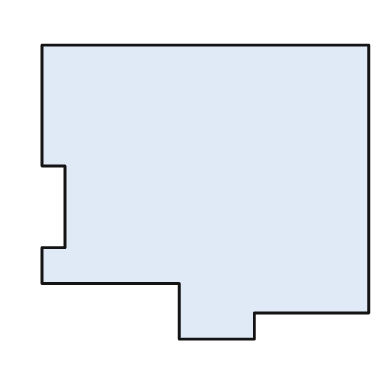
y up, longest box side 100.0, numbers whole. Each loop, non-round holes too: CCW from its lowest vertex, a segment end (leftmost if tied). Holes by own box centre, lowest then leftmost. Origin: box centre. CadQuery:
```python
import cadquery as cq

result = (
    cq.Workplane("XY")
    .moveTo(-8.0, -45.0)
    .lineTo(15.0, -45.0)
    .lineTo(15.0, -37.0)
    .lineTo(50.0, -37.0)
    .lineTo(50.0, 45.0)
    .lineTo(-50.0, 45.0)
    .lineTo(-50.0, 8.0)
    .lineTo(-43.0, 8.0)
    .lineTo(-43.0, -17.0)
    .lineTo(-50.0, -17.0)
    .lineTo(-50.0, -28.0)
    .lineTo(-8.0, -28.0)
    .close()
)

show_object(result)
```